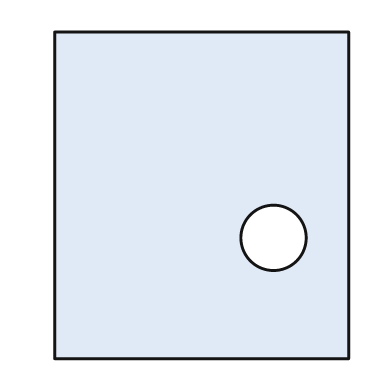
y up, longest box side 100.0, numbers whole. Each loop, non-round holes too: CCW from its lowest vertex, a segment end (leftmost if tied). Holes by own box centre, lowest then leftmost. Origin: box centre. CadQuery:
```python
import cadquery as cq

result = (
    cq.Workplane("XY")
    .moveTo(-45.0, -50.0)
    .lineTo(45.0, -50.0)
    .lineTo(45.0, 50.0)
    .lineTo(-45.0, 50.0)
    .close()
    .moveTo(22.0, -13.0)
    .circle(10.0)
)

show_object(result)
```